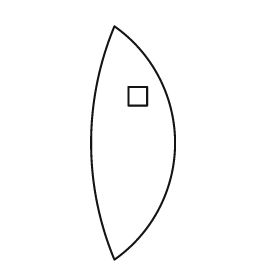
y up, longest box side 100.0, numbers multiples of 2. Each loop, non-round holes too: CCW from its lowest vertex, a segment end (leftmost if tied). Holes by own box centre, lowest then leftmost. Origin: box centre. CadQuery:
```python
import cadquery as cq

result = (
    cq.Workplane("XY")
    .moveTo(-8.0, -50.0)
    .threePointArc((18.0, 0.0), (-8.0, 50.0))
    .threePointArc((-18.0, 0.0), (-8.0, -50.0))
    .close()
    .moveTo(-2.0, 16.0)
    .lineTo(6.0, 16.0)
    .lineTo(6.0, 24.0)
    .lineTo(-2.0, 24.0)
    .close()
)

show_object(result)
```